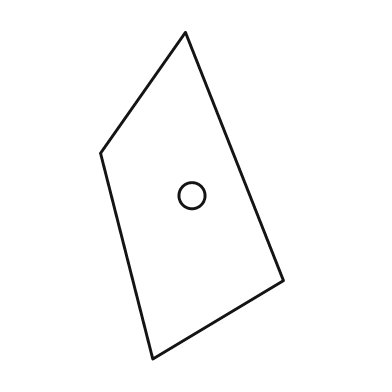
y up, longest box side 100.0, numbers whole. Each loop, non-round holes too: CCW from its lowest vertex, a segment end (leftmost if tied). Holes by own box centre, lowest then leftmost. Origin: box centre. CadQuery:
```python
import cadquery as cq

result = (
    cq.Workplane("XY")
    .moveTo(-12.0, -50.0)
    .lineTo(28.0, -26.0)
    .lineTo(-2.0, 50.0)
    .lineTo(-28.0, 13.0)
    .close()
    .moveTo(0.0, 0.0)
    .circle(4.0)
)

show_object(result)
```